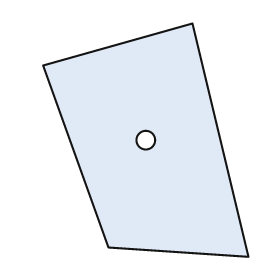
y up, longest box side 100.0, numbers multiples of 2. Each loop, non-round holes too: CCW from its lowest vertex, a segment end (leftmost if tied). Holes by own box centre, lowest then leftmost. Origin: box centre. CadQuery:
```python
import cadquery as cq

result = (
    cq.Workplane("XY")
    .moveTo(44.0, -50.0)
    .lineTo(20.0, 50.0)
    .lineTo(-44.0, 32.0)
    .lineTo(-16.0, -46.0)
    .close()
    .moveTo(0.0, 0.0)
    .circle(4.0)
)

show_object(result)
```